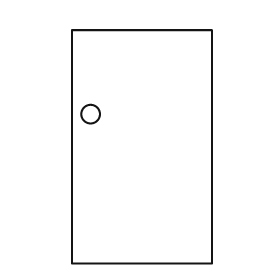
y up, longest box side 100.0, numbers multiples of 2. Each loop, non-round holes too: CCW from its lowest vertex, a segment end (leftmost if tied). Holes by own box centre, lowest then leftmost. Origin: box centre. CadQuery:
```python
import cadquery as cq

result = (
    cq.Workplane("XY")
    .moveTo(-30.0, -50.0)
    .lineTo(30.0, -50.0)
    .lineTo(30.0, 50.0)
    .lineTo(-30.0, 50.0)
    .close()
    .moveTo(-22.0, 14.0)
    .circle(4.0)
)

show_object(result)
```